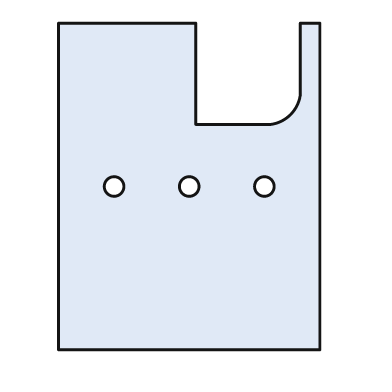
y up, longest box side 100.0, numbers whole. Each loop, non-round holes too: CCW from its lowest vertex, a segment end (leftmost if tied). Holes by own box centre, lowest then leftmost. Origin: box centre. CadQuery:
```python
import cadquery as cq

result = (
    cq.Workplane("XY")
    .moveTo(-40.0, -50.0)
    .lineTo(40.0, -50.0)
    .lineTo(40.0, 50.0)
    .lineTo(34.0, 50.0)
    .lineTo(34.0, 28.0)
    .threePointArc((31.0, 22.0), (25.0, 19.0))
    .lineTo(2.0, 19.0)
    .lineTo(2.0, 50.0)
    .lineTo(-40.0, 50.0)
    .close()
    .moveTo(-23.0, 0.0)
    .circle(3.0)
    .moveTo(0.0, 0.0)
    .circle(3.0)
    .moveTo(23.0, 0.0)
    .circle(3.0)
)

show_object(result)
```